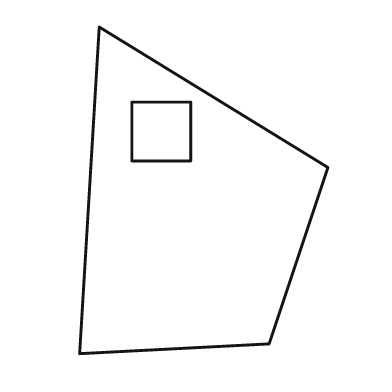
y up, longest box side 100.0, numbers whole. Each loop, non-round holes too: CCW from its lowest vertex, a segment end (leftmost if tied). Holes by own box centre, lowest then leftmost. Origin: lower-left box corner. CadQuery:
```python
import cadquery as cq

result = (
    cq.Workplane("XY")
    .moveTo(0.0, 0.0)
    .lineTo(58.0, 3.0)
    .lineTo(76.0, 57.0)
    .lineTo(6.0, 100.0)
    .close()
    .moveTo(16.0, 59.0)
    .lineTo(34.0, 59.0)
    .lineTo(34.0, 77.0)
    .lineTo(16.0, 77.0)
    .close()
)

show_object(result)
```